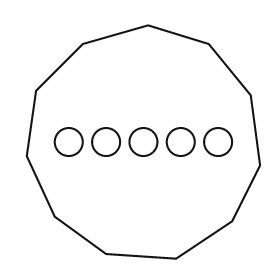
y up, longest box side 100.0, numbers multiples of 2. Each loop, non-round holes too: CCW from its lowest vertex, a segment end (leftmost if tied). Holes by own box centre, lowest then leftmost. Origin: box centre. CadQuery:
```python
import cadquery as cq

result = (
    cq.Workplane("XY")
    .moveTo(14.0, -50.0)
    .lineTo(38.0, -34.0)
    .lineTo(50.0, -10.0)
    .lineTo(46.0, 20.0)
    .lineTo(28.0, 42.0)
    .lineTo(2.0, 50.0)
    .lineTo(-26.0, 42.0)
    .lineTo(-46.0, 22.0)
    .lineTo(-50.0, -6.0)
    .lineTo(-38.0, -32.0)
    .lineTo(-16.0, -48.0)
    .close()
    .moveTo(-32.0, 0.0)
    .circle(6.0)
    .moveTo(-16.0, 0.0)
    .circle(6.0)
    .moveTo(0.0, 0.0)
    .circle(6.0)
    .moveTo(16.0, 0.0)
    .circle(6.0)
    .moveTo(32.0, 0.0)
    .circle(6.0)
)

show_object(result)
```